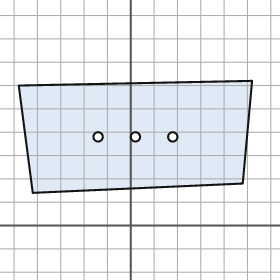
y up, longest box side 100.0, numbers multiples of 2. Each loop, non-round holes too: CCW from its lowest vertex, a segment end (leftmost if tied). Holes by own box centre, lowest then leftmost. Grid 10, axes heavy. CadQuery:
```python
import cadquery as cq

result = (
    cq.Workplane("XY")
    .moveTo(-42.0, 14.0)
    .lineTo(48.0, 18.0)
    .lineTo(52.0, 62.0)
    .lineTo(-48.0, 60.0)
    .close()
    .moveTo(-14.0, 38.0)
    .circle(2.0)
    .moveTo(2.0, 38.0)
    .circle(2.0)
    .moveTo(18.0, 38.0)
    .circle(2.0)
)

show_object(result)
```